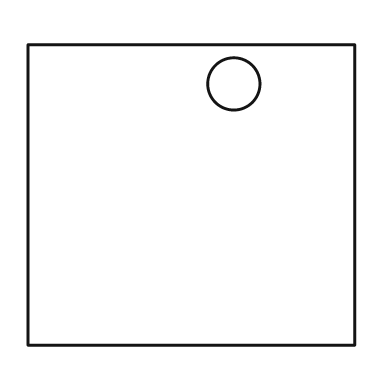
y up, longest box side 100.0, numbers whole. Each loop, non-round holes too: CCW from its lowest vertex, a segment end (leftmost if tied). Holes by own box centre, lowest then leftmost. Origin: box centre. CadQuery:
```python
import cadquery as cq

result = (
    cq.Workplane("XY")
    .moveTo(-50.0, -46.0)
    .lineTo(50.0, -46.0)
    .lineTo(50.0, 46.0)
    .lineTo(-50.0, 46.0)
    .close()
    .moveTo(13.0, 34.0)
    .circle(8.0)
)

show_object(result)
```